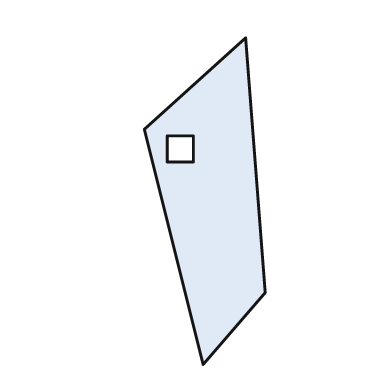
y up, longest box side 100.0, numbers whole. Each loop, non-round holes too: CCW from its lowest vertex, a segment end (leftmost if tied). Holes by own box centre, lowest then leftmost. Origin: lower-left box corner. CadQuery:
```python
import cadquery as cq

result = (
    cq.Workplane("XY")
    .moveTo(18.0, 0.0)
    .lineTo(37.0, 22.0)
    .lineTo(31.0, 100.0)
    .lineTo(0.0, 72.0)
    .close()
    .moveTo(7.0, 62.0)
    .lineTo(15.0, 62.0)
    .lineTo(15.0, 70.0)
    .lineTo(7.0, 70.0)
    .close()
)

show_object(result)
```